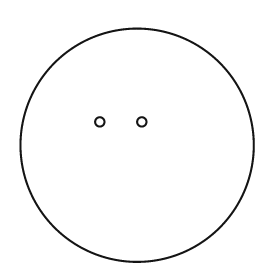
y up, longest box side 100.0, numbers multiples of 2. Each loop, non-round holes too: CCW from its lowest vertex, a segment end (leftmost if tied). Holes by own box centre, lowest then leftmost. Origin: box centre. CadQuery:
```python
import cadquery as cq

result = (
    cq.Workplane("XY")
    .moveTo(0.0, 0.0)
    .circle(50.0)
    .moveTo(-16.0, 10.0)
    .circle(2.0)
    .moveTo(2.0, 10.0)
    .circle(2.0)
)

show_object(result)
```